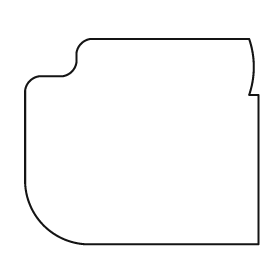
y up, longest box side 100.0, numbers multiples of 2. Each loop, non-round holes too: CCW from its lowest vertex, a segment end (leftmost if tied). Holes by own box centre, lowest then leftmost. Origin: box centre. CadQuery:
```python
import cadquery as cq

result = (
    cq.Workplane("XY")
    .moveTo(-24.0, -44.0)
    .lineTo(50.0, -44.0)
    .lineTo(50.0, 20.0)
    .lineTo(46.0, 20.0)
    .threePointArc((48.0, 32.0), (46.0, 44.0))
    .lineTo(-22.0, 44.0)
    .threePointArc((-26.0, 42.0), (-28.0, 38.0))
    .lineTo(-28.0, 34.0)
    .threePointArc((-30.0, 30.0), (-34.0, 28.0))
    .lineTo(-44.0, 28.0)
    .threePointArc((-48.0, 26.0), (-50.0, 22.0))
    .lineTo(-50.0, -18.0)
    .threePointArc((-42.0, -36.0), (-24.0, -44.0))
    .close()
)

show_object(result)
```